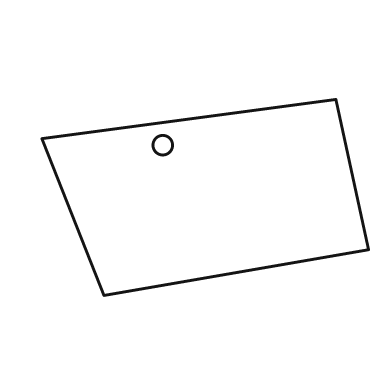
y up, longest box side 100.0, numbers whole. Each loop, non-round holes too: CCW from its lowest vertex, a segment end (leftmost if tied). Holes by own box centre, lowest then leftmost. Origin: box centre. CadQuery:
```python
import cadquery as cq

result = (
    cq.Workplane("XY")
    .moveTo(-31.0, -30.0)
    .lineTo(50.0, -16.0)
    .lineTo(40.0, 30.0)
    .lineTo(-50.0, 18.0)
    .close()
    .moveTo(-13.0, 16.0)
    .circle(3.0)
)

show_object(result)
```